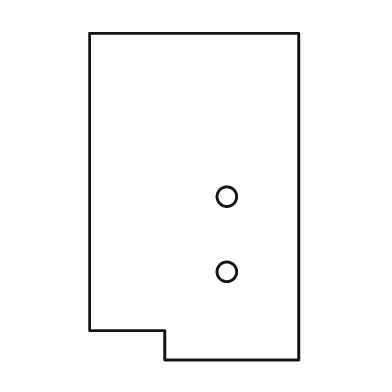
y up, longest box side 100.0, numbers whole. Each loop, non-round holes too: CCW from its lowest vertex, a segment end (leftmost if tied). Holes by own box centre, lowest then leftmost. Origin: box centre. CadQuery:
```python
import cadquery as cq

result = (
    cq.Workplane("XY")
    .moveTo(-9.0, -50.0)
    .lineTo(32.0, -50.0)
    .lineTo(32.0, 50.0)
    .lineTo(-32.0, 50.0)
    .lineTo(-32.0, -41.0)
    .lineTo(-9.0, -41.0)
    .close()
    .moveTo(10.0, -23.0)
    .circle(3.0)
    .moveTo(10.0, 0.0)
    .circle(3.0)
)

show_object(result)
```